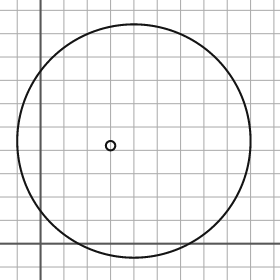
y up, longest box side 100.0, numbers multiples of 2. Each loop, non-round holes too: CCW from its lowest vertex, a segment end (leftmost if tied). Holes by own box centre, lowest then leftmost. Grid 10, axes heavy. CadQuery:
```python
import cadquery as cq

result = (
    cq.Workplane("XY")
    .moveTo(40.0, 44.0)
    .circle(50.0)
    .moveTo(30.0, 42.0)
    .circle(2.0)
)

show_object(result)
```